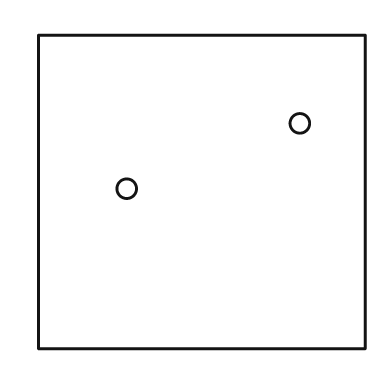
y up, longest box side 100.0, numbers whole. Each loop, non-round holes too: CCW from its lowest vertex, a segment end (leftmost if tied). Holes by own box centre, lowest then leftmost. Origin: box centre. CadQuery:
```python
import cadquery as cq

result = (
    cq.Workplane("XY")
    .moveTo(-50.0, -48.0)
    .lineTo(50.0, -48.0)
    .lineTo(50.0, 48.0)
    .lineTo(-50.0, 48.0)
    .close()
    .moveTo(-23.0, 1.0)
    .circle(3.0)
    .moveTo(30.0, 21.0)
    .circle(3.0)
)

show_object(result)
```